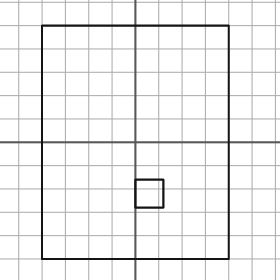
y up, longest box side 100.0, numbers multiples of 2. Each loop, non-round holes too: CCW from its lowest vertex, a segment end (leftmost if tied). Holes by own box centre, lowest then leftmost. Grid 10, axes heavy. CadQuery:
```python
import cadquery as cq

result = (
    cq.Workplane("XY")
    .moveTo(-40.0, -50.0)
    .lineTo(40.0, -50.0)
    .lineTo(40.0, 50.0)
    .lineTo(-40.0, 50.0)
    .close()
    .moveTo(0.0, -28.0)
    .lineTo(12.0, -28.0)
    .lineTo(12.0, -16.0)
    .lineTo(0.0, -16.0)
    .close()
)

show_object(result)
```